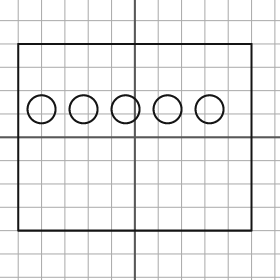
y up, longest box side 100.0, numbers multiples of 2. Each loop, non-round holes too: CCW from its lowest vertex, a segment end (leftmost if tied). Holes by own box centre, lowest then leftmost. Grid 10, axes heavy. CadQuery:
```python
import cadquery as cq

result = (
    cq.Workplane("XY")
    .moveTo(-50.0, -40.0)
    .lineTo(50.0, -40.0)
    .lineTo(50.0, 40.0)
    .lineTo(-50.0, 40.0)
    .close()
    .moveTo(-40.0, 12.0)
    .circle(6.0)
    .moveTo(-22.0, 12.0)
    .circle(6.0)
    .moveTo(-4.0, 12.0)
    .circle(6.0)
    .moveTo(14.0, 12.0)
    .circle(6.0)
    .moveTo(32.0, 12.0)
    .circle(6.0)
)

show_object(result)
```